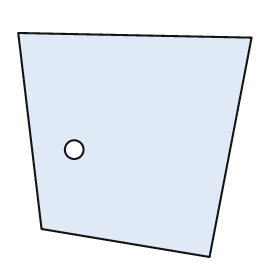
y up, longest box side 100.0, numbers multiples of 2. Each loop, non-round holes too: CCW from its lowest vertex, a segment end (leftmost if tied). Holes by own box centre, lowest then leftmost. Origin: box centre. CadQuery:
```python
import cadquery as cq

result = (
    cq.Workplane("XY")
    .moveTo(32.0, -48.0)
    .lineTo(50.0, 46.0)
    .lineTo(-50.0, 48.0)
    .lineTo(-40.0, -36.0)
    .close()
    .moveTo(-26.0, -2.0)
    .circle(4.0)
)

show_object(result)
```